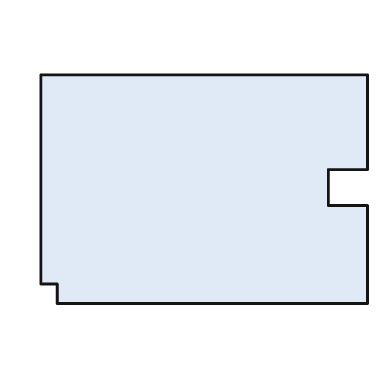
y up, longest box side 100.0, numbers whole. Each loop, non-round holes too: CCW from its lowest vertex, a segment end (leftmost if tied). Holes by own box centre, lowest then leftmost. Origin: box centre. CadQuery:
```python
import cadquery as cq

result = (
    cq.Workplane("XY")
    .moveTo(-45.0, -35.0)
    .lineTo(50.0, -35.0)
    .lineTo(50.0, -5.0)
    .lineTo(38.0, -5.0)
    .lineTo(38.0, 6.0)
    .lineTo(50.0, 6.0)
    .lineTo(50.0, 35.0)
    .lineTo(-50.0, 35.0)
    .lineTo(-50.0, -29.0)
    .lineTo(-45.0, -29.0)
    .close()
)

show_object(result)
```